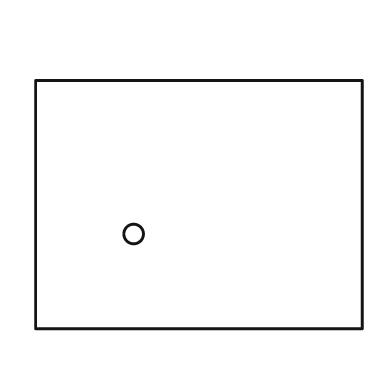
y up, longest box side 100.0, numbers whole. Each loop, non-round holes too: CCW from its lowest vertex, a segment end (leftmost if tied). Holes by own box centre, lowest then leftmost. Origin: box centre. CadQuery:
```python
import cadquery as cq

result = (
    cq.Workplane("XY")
    .moveTo(-50.0, -38.0)
    .lineTo(50.0, -38.0)
    .lineTo(50.0, 38.0)
    .lineTo(-50.0, 38.0)
    .close()
    .moveTo(-20.0, -9.0)
    .circle(3.0)
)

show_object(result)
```